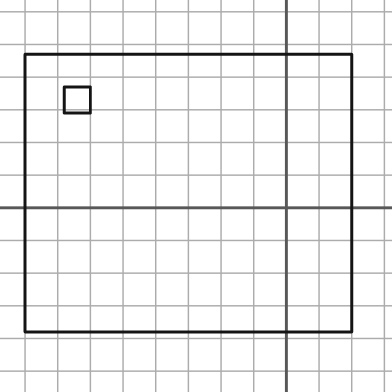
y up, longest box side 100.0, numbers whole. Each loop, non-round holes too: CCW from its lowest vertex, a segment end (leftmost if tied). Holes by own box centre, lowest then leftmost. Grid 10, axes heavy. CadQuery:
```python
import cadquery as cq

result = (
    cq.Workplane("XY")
    .moveTo(-80.0, -38.0)
    .lineTo(20.0, -38.0)
    .lineTo(20.0, 47.0)
    .lineTo(-80.0, 47.0)
    .close()
    .moveTo(-68.0, 29.0)
    .lineTo(-60.0, 29.0)
    .lineTo(-60.0, 37.0)
    .lineTo(-68.0, 37.0)
    .close()
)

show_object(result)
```